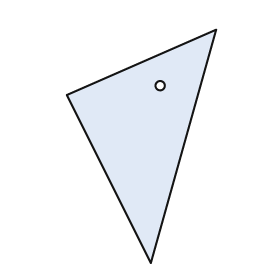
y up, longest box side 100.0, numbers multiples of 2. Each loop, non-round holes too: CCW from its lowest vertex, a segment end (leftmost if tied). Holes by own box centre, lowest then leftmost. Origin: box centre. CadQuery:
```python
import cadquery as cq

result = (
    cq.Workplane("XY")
    .moveTo(4.0, -50.0)
    .lineTo(32.0, 50.0)
    .lineTo(-32.0, 22.0)
    .close()
    .moveTo(8.0, 26.0)
    .circle(2.0)
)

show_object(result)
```